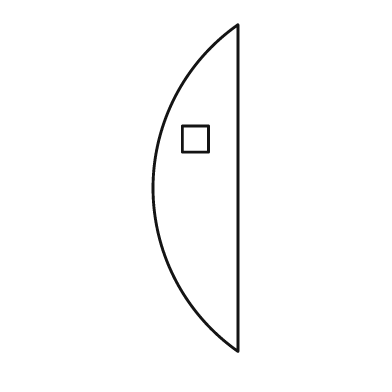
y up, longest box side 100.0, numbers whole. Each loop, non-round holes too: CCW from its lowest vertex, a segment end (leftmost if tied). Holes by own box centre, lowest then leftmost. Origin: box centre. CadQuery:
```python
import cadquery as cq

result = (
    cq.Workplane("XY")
    .moveTo(13.0, -50.0)
    .lineTo(13.0, 50.0)
    .threePointArc((-13.0, 0.0), (13.0, -50.0))
    .close()
    .moveTo(-4.0, 11.0)
    .lineTo(4.0, 11.0)
    .lineTo(4.0, 19.0)
    .lineTo(-4.0, 19.0)
    .close()
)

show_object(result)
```